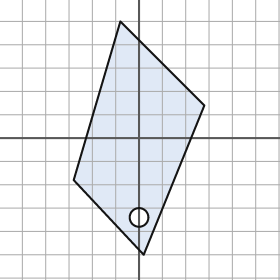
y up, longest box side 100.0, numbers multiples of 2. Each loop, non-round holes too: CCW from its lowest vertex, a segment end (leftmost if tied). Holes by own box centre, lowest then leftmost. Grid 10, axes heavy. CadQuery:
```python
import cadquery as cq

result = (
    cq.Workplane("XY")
    .moveTo(2.0, -50.0)
    .lineTo(28.0, 14.0)
    .lineTo(-8.0, 50.0)
    .lineTo(-28.0, -18.0)
    .close()
    .moveTo(0.0, -34.0)
    .circle(4.0)
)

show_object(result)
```